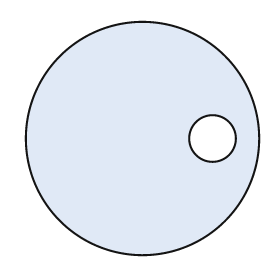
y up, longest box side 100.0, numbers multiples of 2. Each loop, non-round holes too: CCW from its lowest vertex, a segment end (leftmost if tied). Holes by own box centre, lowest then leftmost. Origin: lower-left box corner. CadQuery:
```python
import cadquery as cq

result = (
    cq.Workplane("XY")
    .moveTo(50.0, 50.0)
    .circle(50.0)
    .moveTo(80.0, 50.0)
    .circle(10.0)
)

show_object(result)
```